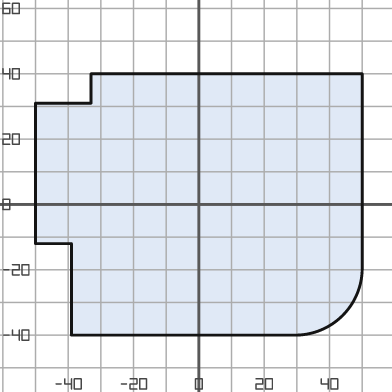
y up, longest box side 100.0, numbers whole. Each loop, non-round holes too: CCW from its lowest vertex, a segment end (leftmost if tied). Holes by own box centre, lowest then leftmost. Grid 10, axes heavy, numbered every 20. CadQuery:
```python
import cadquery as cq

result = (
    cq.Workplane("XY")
    .moveTo(-39.0, -40.0)
    .lineTo(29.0, -40.0)
    .threePointArc((44.0, -34.0), (50.0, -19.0))
    .lineTo(50.0, 40.0)
    .lineTo(-33.0, 40.0)
    .lineTo(-33.0, 31.0)
    .lineTo(-50.0, 31.0)
    .lineTo(-50.0, -12.0)
    .lineTo(-39.0, -12.0)
    .close()
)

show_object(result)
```